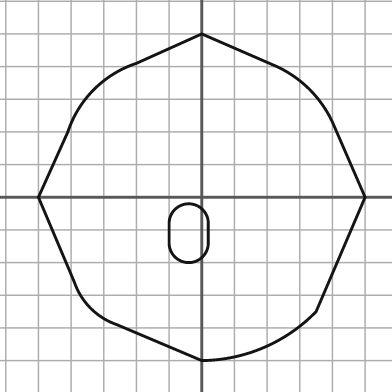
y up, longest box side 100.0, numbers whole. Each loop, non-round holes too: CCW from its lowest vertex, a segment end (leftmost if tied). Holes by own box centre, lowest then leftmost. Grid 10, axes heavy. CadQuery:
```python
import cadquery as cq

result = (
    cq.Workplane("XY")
    .moveTo(0.0, -50.0)
    .threePointArc((19.0, -46.0), (35.0, -35.0))
    .lineTo(50.0, 0.0)
    .lineTo(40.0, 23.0)
    .threePointArc((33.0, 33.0), (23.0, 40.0))
    .lineTo(0.0, 50.0)
    .lineTo(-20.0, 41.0)
    .threePointArc((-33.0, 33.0), (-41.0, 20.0))
    .lineTo(-50.0, 0.0)
    .lineTo(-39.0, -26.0)
    .threePointArc((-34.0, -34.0), (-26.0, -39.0))
    .close()
    .moveTo(-10.0, -14.0)
    .threePointArc((-4.0, -20.0), (2.0, -14.0))
    .lineTo(2.0, -8.0)
    .threePointArc((-4.0, -2.0), (-10.0, -8.0))
    .close()
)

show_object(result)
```